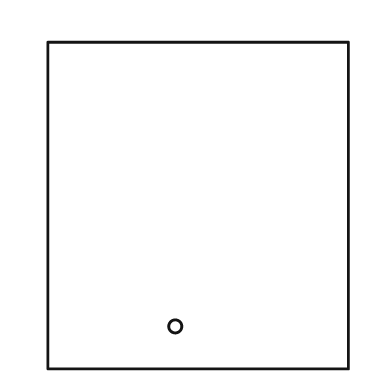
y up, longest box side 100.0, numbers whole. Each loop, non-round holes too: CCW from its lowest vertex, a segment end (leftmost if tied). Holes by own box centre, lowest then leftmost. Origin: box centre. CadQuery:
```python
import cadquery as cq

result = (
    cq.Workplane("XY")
    .moveTo(-46.0, -50.0)
    .lineTo(46.0, -50.0)
    .lineTo(46.0, 50.0)
    .lineTo(-46.0, 50.0)
    .close()
    .moveTo(-7.0, -37.0)
    .circle(2.0)
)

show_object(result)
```